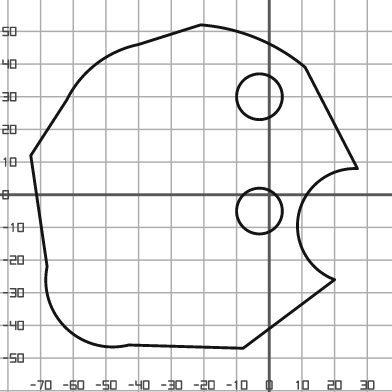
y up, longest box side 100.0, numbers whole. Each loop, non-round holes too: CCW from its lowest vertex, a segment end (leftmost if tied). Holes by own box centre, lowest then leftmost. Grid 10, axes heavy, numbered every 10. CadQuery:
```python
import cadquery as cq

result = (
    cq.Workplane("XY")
    .moveTo(-8.0, -47.0)
    .lineTo(20.0, -26.0)
    .threePointArc((9.0, -6.0), (27.0, 8.0))
    .lineTo(11.0, 39.0)
    .threePointArc((-4.0, 48.0), (-21.0, 52.0))
    .lineTo(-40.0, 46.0)
    .threePointArc((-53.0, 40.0), (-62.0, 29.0))
    .lineTo(-73.0, 12.0)
    .lineTo(-68.0, -22.0)
    .threePointArc((-62.0, -41.0), (-43.0, -46.0))
    .close()
    .moveTo(-3.0, -5.0)
    .circle(7.0)
    .moveTo(-3.0, 30.0)
    .circle(7.0)
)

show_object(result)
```